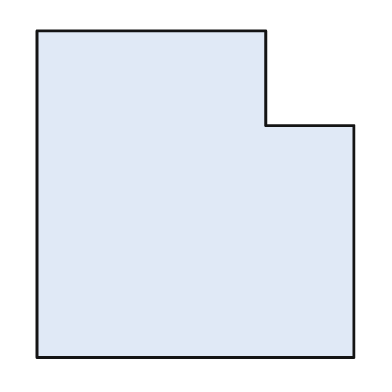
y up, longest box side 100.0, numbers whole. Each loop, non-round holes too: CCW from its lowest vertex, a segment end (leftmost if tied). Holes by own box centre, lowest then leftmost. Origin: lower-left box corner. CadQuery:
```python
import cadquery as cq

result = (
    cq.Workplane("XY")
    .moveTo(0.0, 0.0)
    .lineTo(97.0, 0.0)
    .lineTo(97.0, 71.0)
    .lineTo(70.0, 71.0)
    .lineTo(70.0, 100.0)
    .lineTo(0.0, 100.0)
    .close()
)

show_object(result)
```